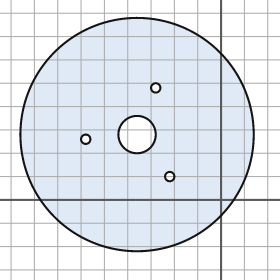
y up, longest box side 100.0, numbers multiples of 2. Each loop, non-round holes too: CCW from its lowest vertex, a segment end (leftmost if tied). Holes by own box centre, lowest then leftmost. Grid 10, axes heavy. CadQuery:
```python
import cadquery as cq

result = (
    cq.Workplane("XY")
    .moveTo(-36.0, 28.0)
    .circle(50.0)
    .moveTo(-22.0, 10.0)
    .circle(2.0)
    .moveTo(-58.0, 26.0)
    .circle(2.0)
    .moveTo(-36.0, 28.0)
    .circle(8.0)
    .moveTo(-28.0, 48.0)
    .circle(2.0)
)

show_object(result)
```